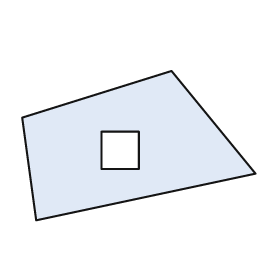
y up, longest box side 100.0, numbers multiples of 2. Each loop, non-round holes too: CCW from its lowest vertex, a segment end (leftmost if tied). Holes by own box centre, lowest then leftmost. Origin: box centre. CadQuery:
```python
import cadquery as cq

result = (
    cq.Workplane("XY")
    .moveTo(-44.0, -32.0)
    .lineTo(50.0, -12.0)
    .lineTo(14.0, 32.0)
    .lineTo(-50.0, 12.0)
    .close()
    .moveTo(-16.0, -10.0)
    .lineTo(0.0, -10.0)
    .lineTo(0.0, 6.0)
    .lineTo(-16.0, 6.0)
    .close()
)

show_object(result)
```